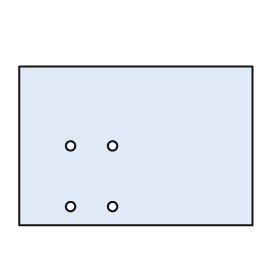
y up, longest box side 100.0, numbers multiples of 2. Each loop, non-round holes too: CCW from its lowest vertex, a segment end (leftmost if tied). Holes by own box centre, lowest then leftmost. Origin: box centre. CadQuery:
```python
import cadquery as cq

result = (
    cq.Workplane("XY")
    .moveTo(-50.0, -34.0)
    .lineTo(50.0, -34.0)
    .lineTo(50.0, 34.0)
    .lineTo(-50.0, 34.0)
    .close()
    .moveTo(-28.0, -26.0)
    .circle(2.0)
    .moveTo(-10.0, -26.0)
    .circle(2.0)
    .moveTo(-28.0, 0.0)
    .circle(2.0)
    .moveTo(-10.0, 0.0)
    .circle(2.0)
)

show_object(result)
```